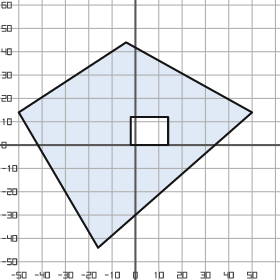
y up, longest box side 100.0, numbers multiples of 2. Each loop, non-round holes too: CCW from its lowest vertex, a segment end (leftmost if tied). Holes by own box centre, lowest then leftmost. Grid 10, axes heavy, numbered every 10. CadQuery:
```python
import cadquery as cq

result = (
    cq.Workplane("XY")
    .moveTo(-16.0, -44.0)
    .lineTo(50.0, 14.0)
    .lineTo(-4.0, 44.0)
    .lineTo(-50.0, 14.0)
    .close()
    .moveTo(-2.0, 0.0)
    .lineTo(14.0, 0.0)
    .lineTo(14.0, 12.0)
    .lineTo(-2.0, 12.0)
    .close()
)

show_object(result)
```